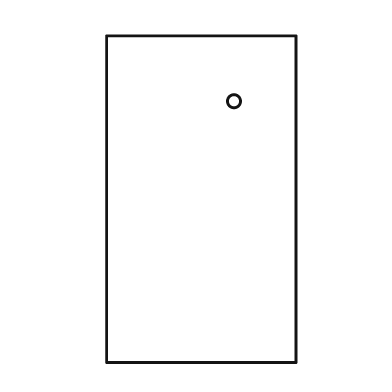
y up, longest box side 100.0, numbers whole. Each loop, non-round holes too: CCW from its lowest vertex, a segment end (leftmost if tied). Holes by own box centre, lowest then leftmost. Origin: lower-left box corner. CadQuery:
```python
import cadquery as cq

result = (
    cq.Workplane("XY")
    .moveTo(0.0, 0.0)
    .lineTo(58.0, 0.0)
    .lineTo(58.0, 100.0)
    .lineTo(0.0, 100.0)
    .close()
    .moveTo(39.0, 80.0)
    .circle(2.0)
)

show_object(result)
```